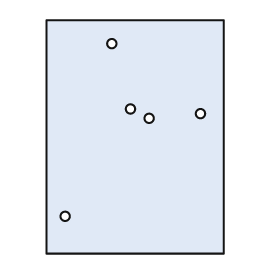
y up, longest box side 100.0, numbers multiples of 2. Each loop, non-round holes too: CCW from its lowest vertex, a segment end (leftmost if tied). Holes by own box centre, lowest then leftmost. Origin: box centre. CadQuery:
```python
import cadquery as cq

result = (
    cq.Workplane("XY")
    .moveTo(-38.0, -50.0)
    .lineTo(38.0, -50.0)
    .lineTo(38.0, 50.0)
    .lineTo(-38.0, 50.0)
    .close()
    .moveTo(-30.0, -34.0)
    .circle(2.0)
    .moveTo(6.0, 8.0)
    .circle(2.0)
    .moveTo(28.0, 10.0)
    .circle(2.0)
    .moveTo(-2.0, 12.0)
    .circle(2.0)
    .moveTo(-10.0, 40.0)
    .circle(2.0)
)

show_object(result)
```